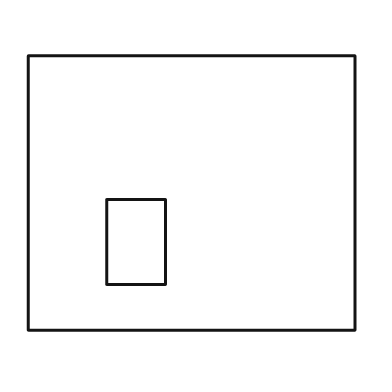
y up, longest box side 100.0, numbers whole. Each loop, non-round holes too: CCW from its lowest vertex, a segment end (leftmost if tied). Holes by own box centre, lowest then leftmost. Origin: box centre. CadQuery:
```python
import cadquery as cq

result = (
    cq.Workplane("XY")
    .moveTo(-50.0, -42.0)
    .lineTo(50.0, -42.0)
    .lineTo(50.0, 42.0)
    .lineTo(-50.0, 42.0)
    .close()
    .moveTo(-26.0, -28.0)
    .lineTo(-8.0, -28.0)
    .lineTo(-8.0, -2.0)
    .lineTo(-26.0, -2.0)
    .close()
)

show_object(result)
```